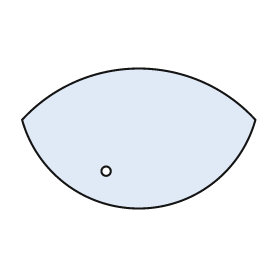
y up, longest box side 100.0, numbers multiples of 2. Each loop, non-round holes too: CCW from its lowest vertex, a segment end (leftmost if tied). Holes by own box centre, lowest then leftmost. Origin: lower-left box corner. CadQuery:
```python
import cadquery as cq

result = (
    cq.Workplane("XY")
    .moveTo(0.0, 38.0)
    .threePointArc((50.0, 0.0), (100.0, 38.0))
    .threePointArc((50.0, 60.0), (0.0, 38.0))
    .close()
    .moveTo(36.0, 16.0)
    .circle(2.0)
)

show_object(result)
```